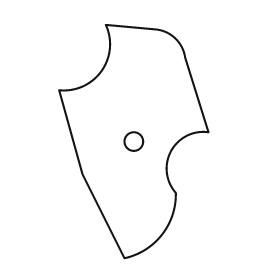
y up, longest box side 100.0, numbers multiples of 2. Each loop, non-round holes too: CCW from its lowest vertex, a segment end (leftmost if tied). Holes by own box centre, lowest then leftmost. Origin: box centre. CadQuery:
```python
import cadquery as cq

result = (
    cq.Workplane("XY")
    .moveTo(-4.0, -50.0)
    .threePointArc((12.0, -40.0), (18.0, -22.0))
    .threePointArc((16.0, -4.0), (32.0, 4.0))
    .lineTo(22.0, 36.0)
    .threePointArc((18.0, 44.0), (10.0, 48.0))
    .lineTo(-12.0, 50.0)
    .threePointArc((-14.0, 30.0), (-32.0, 22.0))
    .lineTo(-22.0, -14.0)
    .close()
    .moveTo(0.0, 0.0)
    .circle(4.0)
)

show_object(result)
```